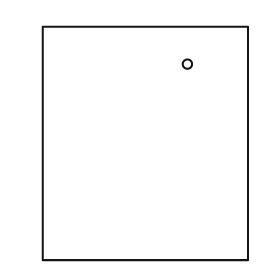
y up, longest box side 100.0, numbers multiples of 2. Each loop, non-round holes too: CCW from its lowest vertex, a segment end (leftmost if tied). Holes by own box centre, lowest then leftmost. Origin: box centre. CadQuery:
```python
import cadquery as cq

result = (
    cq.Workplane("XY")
    .moveTo(-44.0, -50.0)
    .lineTo(44.0, -50.0)
    .lineTo(44.0, 50.0)
    .lineTo(-44.0, 50.0)
    .close()
    .moveTo(18.0, 34.0)
    .circle(2.0)
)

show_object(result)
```